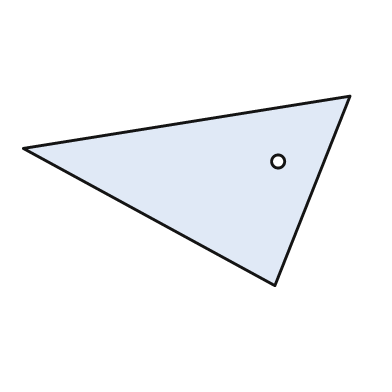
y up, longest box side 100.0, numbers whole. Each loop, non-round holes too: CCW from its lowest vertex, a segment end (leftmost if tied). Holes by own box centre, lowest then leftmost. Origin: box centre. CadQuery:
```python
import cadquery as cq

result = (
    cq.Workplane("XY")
    .moveTo(27.0, -29.0)
    .lineTo(50.0, 29.0)
    .lineTo(-50.0, 13.0)
    .close()
    .moveTo(28.0, 9.0)
    .circle(2.0)
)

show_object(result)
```